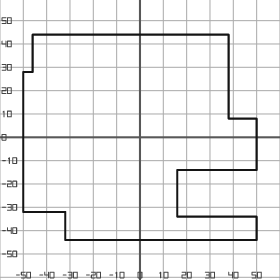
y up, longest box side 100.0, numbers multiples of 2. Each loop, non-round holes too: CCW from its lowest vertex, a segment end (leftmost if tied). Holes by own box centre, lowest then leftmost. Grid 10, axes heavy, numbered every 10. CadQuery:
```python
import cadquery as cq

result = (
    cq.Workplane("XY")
    .moveTo(-32.0, -44.0)
    .lineTo(50.0, -44.0)
    .lineTo(50.0, -34.0)
    .lineTo(16.0, -34.0)
    .lineTo(16.0, -14.0)
    .lineTo(50.0, -14.0)
    .lineTo(50.0, 8.0)
    .lineTo(38.0, 8.0)
    .lineTo(38.0, 44.0)
    .lineTo(-46.0, 44.0)
    .lineTo(-46.0, 28.0)
    .lineTo(-50.0, 28.0)
    .lineTo(-50.0, -32.0)
    .lineTo(-32.0, -32.0)
    .close()
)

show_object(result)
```